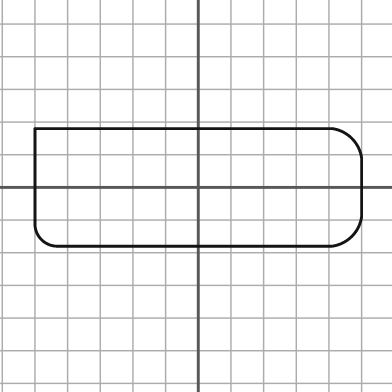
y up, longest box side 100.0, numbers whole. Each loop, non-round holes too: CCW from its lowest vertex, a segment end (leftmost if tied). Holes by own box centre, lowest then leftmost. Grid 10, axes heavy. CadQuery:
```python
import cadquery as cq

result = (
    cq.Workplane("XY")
    .moveTo(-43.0, -18.0)
    .lineTo(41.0, -18.0)
    .threePointArc((47.0, -15.0), (50.0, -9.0))
    .lineTo(50.0, 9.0)
    .threePointArc((47.0, 15.0), (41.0, 18.0))
    .lineTo(-50.0, 18.0)
    .lineTo(-50.0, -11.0)
    .threePointArc((-48.0, -16.0), (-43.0, -18.0))
    .close()
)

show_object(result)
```